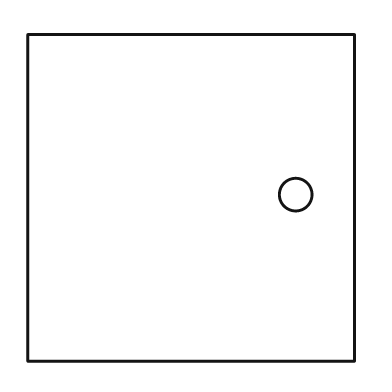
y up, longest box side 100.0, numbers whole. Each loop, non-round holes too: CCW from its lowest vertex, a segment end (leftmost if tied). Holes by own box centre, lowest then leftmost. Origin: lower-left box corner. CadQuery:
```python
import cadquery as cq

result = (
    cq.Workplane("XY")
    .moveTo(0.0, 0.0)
    .lineTo(100.0, 0.0)
    .lineTo(100.0, 100.0)
    .lineTo(0.0, 100.0)
    .close()
    .moveTo(82.0, 51.0)
    .circle(5.0)
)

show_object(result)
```